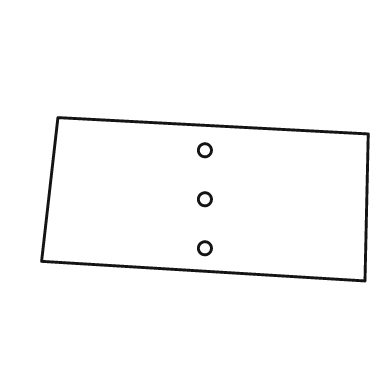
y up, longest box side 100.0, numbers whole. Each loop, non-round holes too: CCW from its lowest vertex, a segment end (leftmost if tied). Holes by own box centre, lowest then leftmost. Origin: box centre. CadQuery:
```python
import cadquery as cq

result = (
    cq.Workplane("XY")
    .moveTo(49.0, -25.0)
    .lineTo(50.0, 20.0)
    .lineTo(-45.0, 25.0)
    .lineTo(-50.0, -19.0)
    .close()
    .moveTo(0.0, -15.0)
    .circle(2.0)
    .moveTo(0.0, 0.0)
    .circle(2.0)
    .moveTo(0.0, 15.0)
    .circle(2.0)
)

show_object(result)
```